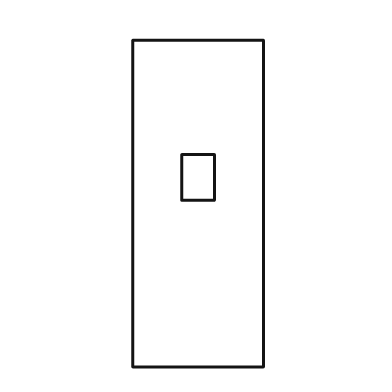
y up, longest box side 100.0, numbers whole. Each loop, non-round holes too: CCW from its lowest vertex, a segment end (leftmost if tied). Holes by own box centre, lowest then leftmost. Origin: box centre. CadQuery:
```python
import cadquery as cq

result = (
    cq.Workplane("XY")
    .moveTo(-20.0, -50.0)
    .lineTo(20.0, -50.0)
    .lineTo(20.0, 50.0)
    .lineTo(-20.0, 50.0)
    .close()
    .moveTo(-5.0, 1.0)
    .lineTo(5.0, 1.0)
    .lineTo(5.0, 15.0)
    .lineTo(-5.0, 15.0)
    .close()
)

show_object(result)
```